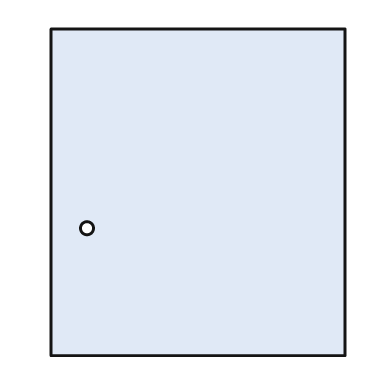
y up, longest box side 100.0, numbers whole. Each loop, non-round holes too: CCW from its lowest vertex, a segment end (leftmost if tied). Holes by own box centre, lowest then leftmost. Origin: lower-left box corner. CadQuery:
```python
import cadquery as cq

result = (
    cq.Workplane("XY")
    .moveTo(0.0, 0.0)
    .lineTo(90.0, 0.0)
    .lineTo(90.0, 100.0)
    .lineTo(0.0, 100.0)
    .close()
    .moveTo(11.0, 39.0)
    .circle(2.0)
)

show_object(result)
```